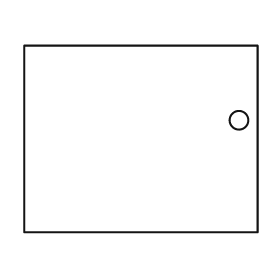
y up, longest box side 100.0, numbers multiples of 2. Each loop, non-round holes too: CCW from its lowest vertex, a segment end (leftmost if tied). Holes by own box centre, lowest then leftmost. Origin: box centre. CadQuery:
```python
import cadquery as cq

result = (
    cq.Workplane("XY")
    .moveTo(-50.0, -40.0)
    .lineTo(50.0, -40.0)
    .lineTo(50.0, 40.0)
    .lineTo(-50.0, 40.0)
    .close()
    .moveTo(42.0, 8.0)
    .circle(4.0)
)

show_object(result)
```